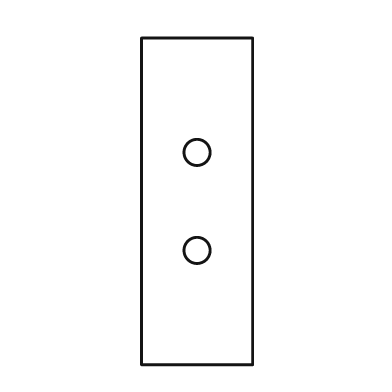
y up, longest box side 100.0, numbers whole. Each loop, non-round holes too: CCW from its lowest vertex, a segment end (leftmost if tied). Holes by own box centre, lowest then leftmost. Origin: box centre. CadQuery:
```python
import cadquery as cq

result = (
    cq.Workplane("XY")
    .moveTo(-17.0, -50.0)
    .lineTo(17.0, -50.0)
    .lineTo(17.0, 50.0)
    .lineTo(-17.0, 50.0)
    .close()
    .moveTo(0.0, -15.0)
    .circle(4.0)
    .moveTo(0.0, 15.0)
    .circle(4.0)
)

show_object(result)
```